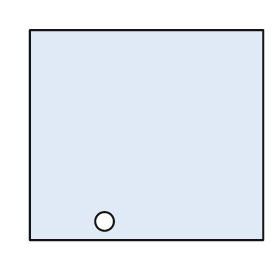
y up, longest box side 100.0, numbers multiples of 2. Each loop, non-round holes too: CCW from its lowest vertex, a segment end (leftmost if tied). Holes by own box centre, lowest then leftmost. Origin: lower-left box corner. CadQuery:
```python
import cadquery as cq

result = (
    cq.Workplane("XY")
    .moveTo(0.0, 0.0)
    .lineTo(100.0, 0.0)
    .lineTo(100.0, 90.0)
    .lineTo(0.0, 90.0)
    .close()
    .moveTo(32.0, 8.0)
    .circle(4.0)
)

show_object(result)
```